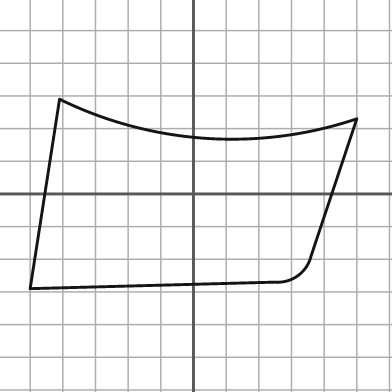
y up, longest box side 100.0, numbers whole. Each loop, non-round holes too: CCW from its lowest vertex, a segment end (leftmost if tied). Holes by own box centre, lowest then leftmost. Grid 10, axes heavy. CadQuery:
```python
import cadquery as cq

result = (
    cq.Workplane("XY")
    .moveTo(-50.0, -29.0)
    .lineTo(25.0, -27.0)
    .threePointArc((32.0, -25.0), (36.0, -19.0))
    .lineTo(50.0, 23.0)
    .threePointArc((4.0, 17.0), (-41.0, 29.0))
    .close()
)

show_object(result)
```